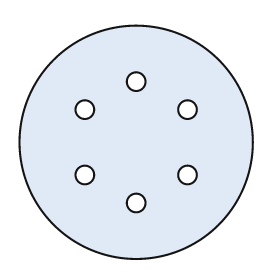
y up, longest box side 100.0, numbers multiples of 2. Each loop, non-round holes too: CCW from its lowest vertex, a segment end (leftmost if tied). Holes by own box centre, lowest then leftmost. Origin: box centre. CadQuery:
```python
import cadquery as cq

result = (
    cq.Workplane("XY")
    .moveTo(0.0, 0.0)
    .circle(50.0)
    .moveTo(0.0, -26.0)
    .circle(4.0)
    .moveTo(-22.0, -14.0)
    .circle(4.0)
    .moveTo(22.0, -14.0)
    .circle(4.0)
    .moveTo(-22.0, 14.0)
    .circle(4.0)
    .moveTo(22.0, 14.0)
    .circle(4.0)
    .moveTo(0.0, 26.0)
    .circle(4.0)
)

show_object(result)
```